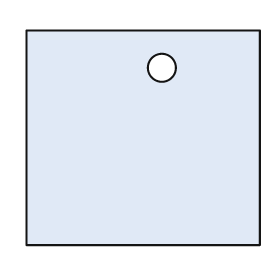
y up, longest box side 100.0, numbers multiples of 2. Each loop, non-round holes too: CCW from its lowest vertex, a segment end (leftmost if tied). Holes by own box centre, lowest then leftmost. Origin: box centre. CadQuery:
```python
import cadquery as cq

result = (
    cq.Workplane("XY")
    .moveTo(-50.0, -46.0)
    .lineTo(50.0, -46.0)
    .lineTo(50.0, 46.0)
    .lineTo(-50.0, 46.0)
    .close()
    .moveTo(8.0, 30.0)
    .circle(6.0)
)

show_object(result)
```